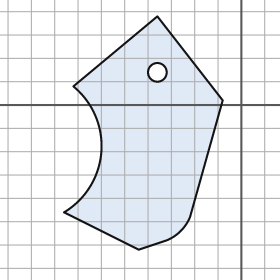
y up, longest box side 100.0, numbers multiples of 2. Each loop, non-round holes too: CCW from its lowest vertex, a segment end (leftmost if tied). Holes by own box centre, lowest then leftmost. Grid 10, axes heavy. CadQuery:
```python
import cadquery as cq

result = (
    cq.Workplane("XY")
    .moveTo(-44.0, -62.0)
    .lineTo(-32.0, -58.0)
    .threePointArc((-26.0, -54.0), (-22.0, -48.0))
    .lineTo(-8.0, 2.0)
    .lineTo(-36.0, 38.0)
    .lineTo(-72.0, 8.0)
    .threePointArc((-60.0, -20.0), (-76.0, -46.0))
    .close()
    .moveTo(-36.0, 14.0)
    .circle(4.0)
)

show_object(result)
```